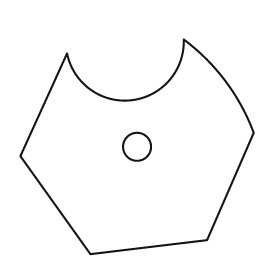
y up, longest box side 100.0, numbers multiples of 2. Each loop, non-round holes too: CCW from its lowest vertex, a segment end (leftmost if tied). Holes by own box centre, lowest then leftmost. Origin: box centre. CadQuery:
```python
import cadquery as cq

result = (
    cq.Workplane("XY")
    .moveTo(-20.0, -46.0)
    .lineTo(30.0, -40.0)
    .lineTo(50.0, 6.0)
    .threePointArc((38.0, 28.0), (20.0, 46.0))
    .threePointArc((-2.0, 20.0), (-30.0, 40.0))
    .lineTo(-50.0, -4.0)
    .close()
    .moveTo(0.0, 0.0)
    .circle(6.0)
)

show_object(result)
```